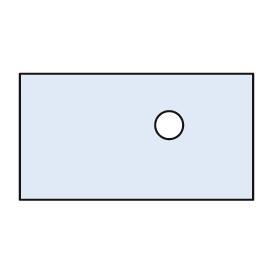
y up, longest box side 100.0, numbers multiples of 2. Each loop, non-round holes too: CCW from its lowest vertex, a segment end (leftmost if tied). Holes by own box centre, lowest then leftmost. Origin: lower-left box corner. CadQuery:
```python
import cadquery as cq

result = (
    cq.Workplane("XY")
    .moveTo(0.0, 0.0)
    .lineTo(100.0, 0.0)
    .lineTo(100.0, 54.0)
    .lineTo(0.0, 54.0)
    .close()
    .moveTo(64.0, 32.0)
    .circle(6.0)
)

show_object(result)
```